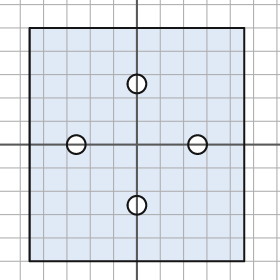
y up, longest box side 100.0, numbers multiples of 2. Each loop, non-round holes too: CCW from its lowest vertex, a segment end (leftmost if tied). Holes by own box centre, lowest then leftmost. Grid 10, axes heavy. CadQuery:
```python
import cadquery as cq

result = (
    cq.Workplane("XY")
    .moveTo(-46.0, -50.0)
    .lineTo(46.0, -50.0)
    .lineTo(46.0, 50.0)
    .lineTo(-46.0, 50.0)
    .close()
    .moveTo(0.0, -26.0)
    .circle(4.0)
    .moveTo(-26.0, 0.0)
    .circle(4.0)
    .moveTo(26.0, 0.0)
    .circle(4.0)
    .moveTo(0.0, 26.0)
    .circle(4.0)
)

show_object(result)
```